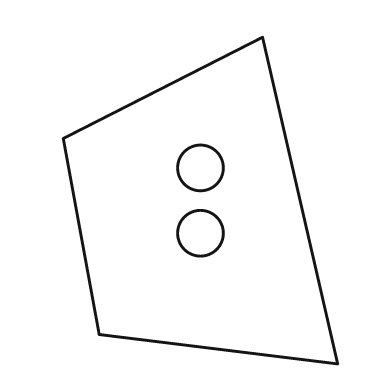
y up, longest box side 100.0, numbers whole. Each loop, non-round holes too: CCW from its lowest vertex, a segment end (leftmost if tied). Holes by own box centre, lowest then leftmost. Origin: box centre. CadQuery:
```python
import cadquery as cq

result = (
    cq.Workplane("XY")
    .moveTo(42.0, -50.0)
    .lineTo(19.0, 50.0)
    .lineTo(-42.0, 19.0)
    .lineTo(-31.0, -41.0)
    .close()
    .moveTo(0.0, -10.0)
    .circle(7.0)
    .moveTo(0.0, 10.0)
    .circle(7.0)
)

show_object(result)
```